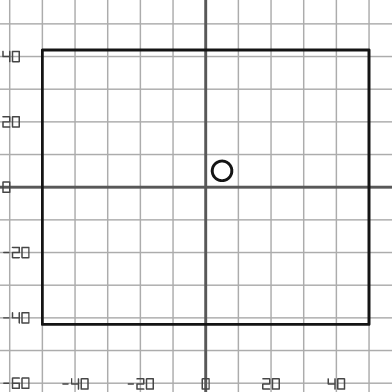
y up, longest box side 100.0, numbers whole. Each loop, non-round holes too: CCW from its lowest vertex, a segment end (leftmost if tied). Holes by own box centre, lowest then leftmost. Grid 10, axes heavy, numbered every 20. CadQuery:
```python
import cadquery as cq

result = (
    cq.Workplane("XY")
    .moveTo(-50.0, -42.0)
    .lineTo(50.0, -42.0)
    .lineTo(50.0, 42.0)
    .lineTo(-50.0, 42.0)
    .close()
    .moveTo(5.0, 5.0)
    .circle(3.0)
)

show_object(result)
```